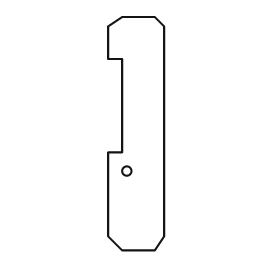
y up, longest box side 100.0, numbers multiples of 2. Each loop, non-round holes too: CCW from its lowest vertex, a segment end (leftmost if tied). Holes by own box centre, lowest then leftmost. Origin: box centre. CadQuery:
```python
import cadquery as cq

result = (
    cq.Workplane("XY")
    .moveTo(-6.0, -50.0)
    .lineTo(8.0, -50.0)
    .lineTo(12.0, -44.0)
    .lineTo(12.0, 46.0)
    .lineTo(8.0, 50.0)
    .lineTo(-6.0, 50.0)
    .lineTo(-12.0, 46.0)
    .lineTo(-12.0, 32.0)
    .lineTo(-6.0, 32.0)
    .lineTo(-6.0, -8.0)
    .lineTo(-12.0, -8.0)
    .lineTo(-12.0, -44.0)
    .close()
    .moveTo(-4.0, -16.0)
    .circle(2.0)
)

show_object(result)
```